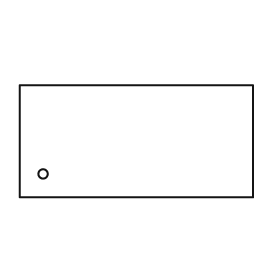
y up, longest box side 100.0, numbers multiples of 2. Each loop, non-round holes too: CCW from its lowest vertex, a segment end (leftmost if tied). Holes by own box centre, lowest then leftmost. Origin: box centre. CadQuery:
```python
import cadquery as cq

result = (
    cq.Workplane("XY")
    .moveTo(-50.0, -24.0)
    .lineTo(50.0, -24.0)
    .lineTo(50.0, 24.0)
    .lineTo(-50.0, 24.0)
    .close()
    .moveTo(-40.0, -14.0)
    .circle(2.0)
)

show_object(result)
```